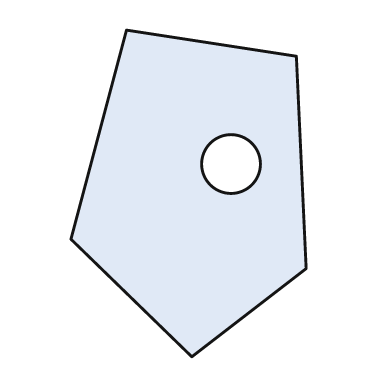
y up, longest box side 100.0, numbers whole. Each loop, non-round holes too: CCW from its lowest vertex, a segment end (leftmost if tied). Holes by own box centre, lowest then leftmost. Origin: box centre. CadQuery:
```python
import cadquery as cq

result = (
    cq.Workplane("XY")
    .moveTo(1.0, -50.0)
    .lineTo(36.0, -23.0)
    .lineTo(33.0, 42.0)
    .lineTo(-19.0, 50.0)
    .lineTo(-36.0, -14.0)
    .close()
    .moveTo(13.0, 9.0)
    .circle(9.0)
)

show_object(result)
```